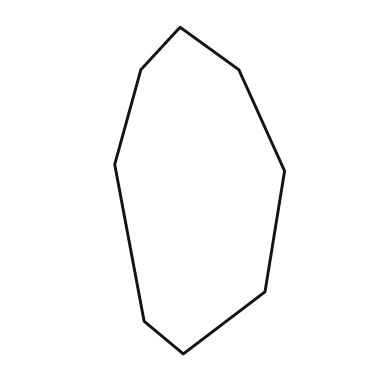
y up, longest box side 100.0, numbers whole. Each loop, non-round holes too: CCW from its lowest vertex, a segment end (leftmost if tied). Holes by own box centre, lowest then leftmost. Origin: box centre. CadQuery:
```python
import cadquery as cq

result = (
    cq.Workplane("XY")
    .moveTo(-5.0, -50.0)
    .lineTo(20.0, -31.0)
    .lineTo(26.0, 6.0)
    .lineTo(12.0, 37.0)
    .lineTo(-6.0, 50.0)
    .lineTo(-18.0, 37.0)
    .lineTo(-26.0, 8.0)
    .lineTo(-17.0, -40.0)
    .close()
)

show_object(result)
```